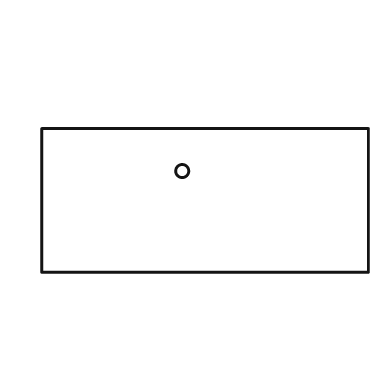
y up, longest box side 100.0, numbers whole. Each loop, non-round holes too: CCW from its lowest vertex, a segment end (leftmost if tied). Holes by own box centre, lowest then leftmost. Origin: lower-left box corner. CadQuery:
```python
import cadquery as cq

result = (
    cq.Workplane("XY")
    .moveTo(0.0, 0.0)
    .lineTo(100.0, 0.0)
    .lineTo(100.0, 44.0)
    .lineTo(0.0, 44.0)
    .close()
    .moveTo(43.0, 31.0)
    .circle(2.0)
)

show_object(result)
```